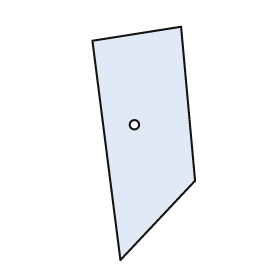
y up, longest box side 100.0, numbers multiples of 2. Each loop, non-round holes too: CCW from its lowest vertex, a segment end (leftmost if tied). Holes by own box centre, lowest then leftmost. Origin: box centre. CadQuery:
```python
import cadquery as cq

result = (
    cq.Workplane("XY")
    .moveTo(-10.0, -50.0)
    .lineTo(22.0, -16.0)
    .lineTo(16.0, 50.0)
    .lineTo(-22.0, 44.0)
    .close()
    .moveTo(-4.0, 8.0)
    .circle(2.0)
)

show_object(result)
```